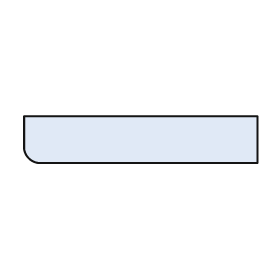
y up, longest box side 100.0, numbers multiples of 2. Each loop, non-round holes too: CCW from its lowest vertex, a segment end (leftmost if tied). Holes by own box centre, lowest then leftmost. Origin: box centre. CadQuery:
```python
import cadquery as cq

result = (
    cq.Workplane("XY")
    .moveTo(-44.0, -10.0)
    .lineTo(50.0, -10.0)
    .lineTo(50.0, 10.0)
    .lineTo(-50.0, 10.0)
    .lineTo(-50.0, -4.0)
    .threePointArc((-48.0, -8.0), (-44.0, -10.0))
    .close()
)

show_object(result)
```